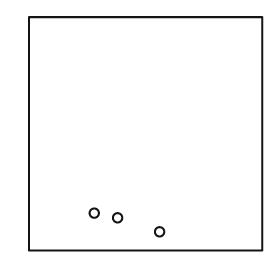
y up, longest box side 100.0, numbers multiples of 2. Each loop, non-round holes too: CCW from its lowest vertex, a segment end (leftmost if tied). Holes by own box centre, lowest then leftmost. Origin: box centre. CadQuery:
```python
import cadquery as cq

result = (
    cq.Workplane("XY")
    .moveTo(-50.0, -50.0)
    .lineTo(50.0, -50.0)
    .lineTo(50.0, 50.0)
    .lineTo(-50.0, 50.0)
    .close()
    .moveTo(6.0, -42.0)
    .circle(2.0)
    .moveTo(-12.0, -36.0)
    .circle(2.0)
    .moveTo(-22.0, -34.0)
    .circle(2.0)
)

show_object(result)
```